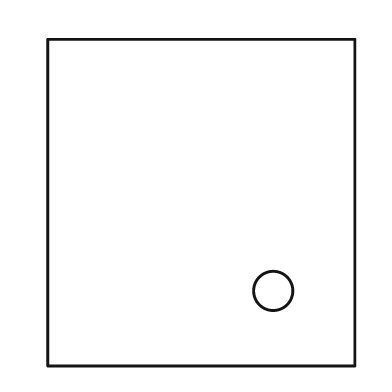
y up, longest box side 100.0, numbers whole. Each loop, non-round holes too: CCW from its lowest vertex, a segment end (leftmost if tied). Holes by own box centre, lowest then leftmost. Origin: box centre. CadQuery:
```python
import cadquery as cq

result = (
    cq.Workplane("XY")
    .moveTo(-47.0, -50.0)
    .lineTo(47.0, -50.0)
    .lineTo(47.0, 50.0)
    .lineTo(-47.0, 50.0)
    .close()
    .moveTo(22.0, -27.0)
    .circle(6.0)
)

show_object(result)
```